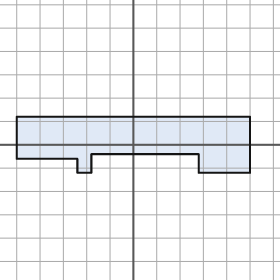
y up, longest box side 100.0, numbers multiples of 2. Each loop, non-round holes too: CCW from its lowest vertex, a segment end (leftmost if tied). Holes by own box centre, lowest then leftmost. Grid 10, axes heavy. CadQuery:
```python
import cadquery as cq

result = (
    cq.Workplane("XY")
    .moveTo(-24.0, -12.0)
    .lineTo(-18.0, -12.0)
    .lineTo(-18.0, -4.0)
    .lineTo(28.0, -4.0)
    .lineTo(28.0, -12.0)
    .lineTo(50.0, -12.0)
    .lineTo(50.0, 12.0)
    .lineTo(-50.0, 12.0)
    .lineTo(-50.0, -6.0)
    .lineTo(-24.0, -6.0)
    .close()
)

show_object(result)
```